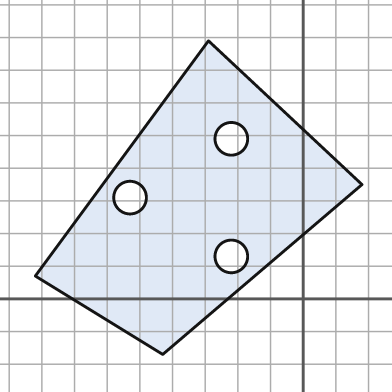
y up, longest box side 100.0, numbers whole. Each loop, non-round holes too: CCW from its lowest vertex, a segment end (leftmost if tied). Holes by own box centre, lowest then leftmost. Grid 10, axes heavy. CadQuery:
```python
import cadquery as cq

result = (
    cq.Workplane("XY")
    .moveTo(-43.0, -17.0)
    .lineTo(18.0, 35.0)
    .lineTo(-29.0, 79.0)
    .lineTo(-82.0, 7.0)
    .close()
    .moveTo(-22.0, 13.0)
    .circle(5.0)
    .moveTo(-53.0, 31.0)
    .circle(5.0)
    .moveTo(-22.0, 49.0)
    .circle(5.0)
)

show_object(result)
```